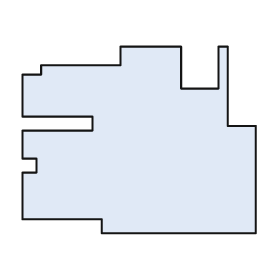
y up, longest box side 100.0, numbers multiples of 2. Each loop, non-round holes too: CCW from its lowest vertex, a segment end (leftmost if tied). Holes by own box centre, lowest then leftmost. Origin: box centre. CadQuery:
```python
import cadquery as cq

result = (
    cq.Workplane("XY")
    .moveTo(-16.0, -40.0)
    .lineTo(50.0, -40.0)
    .lineTo(50.0, 6.0)
    .lineTo(38.0, 6.0)
    .lineTo(38.0, 40.0)
    .lineTo(34.0, 40.0)
    .lineTo(34.0, 22.0)
    .lineTo(18.0, 22.0)
    .lineTo(18.0, 40.0)
    .lineTo(-8.0, 40.0)
    .lineTo(-8.0, 32.0)
    .lineTo(-42.0, 32.0)
    .lineTo(-42.0, 28.0)
    .lineTo(-50.0, 28.0)
    .lineTo(-50.0, 10.0)
    .lineTo(-20.0, 10.0)
    .lineTo(-20.0, 4.0)
    .lineTo(-50.0, 4.0)
    .lineTo(-50.0, -8.0)
    .lineTo(-44.0, -8.0)
    .lineTo(-44.0, -14.0)
    .lineTo(-50.0, -14.0)
    .lineTo(-50.0, -34.0)
    .lineTo(-16.0, -34.0)
    .close()
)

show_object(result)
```